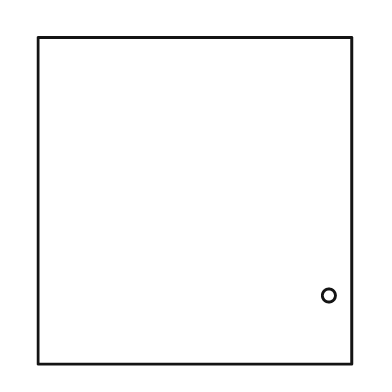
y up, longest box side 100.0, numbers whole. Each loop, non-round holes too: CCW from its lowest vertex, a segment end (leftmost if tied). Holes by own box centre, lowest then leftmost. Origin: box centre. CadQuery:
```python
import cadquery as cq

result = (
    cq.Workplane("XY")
    .moveTo(-48.0, -50.0)
    .lineTo(48.0, -50.0)
    .lineTo(48.0, 50.0)
    .lineTo(-48.0, 50.0)
    .close()
    .moveTo(41.0, -29.0)
    .circle(2.0)
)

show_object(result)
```